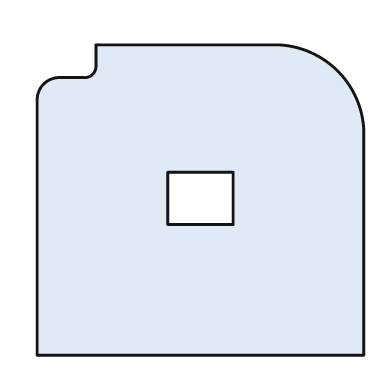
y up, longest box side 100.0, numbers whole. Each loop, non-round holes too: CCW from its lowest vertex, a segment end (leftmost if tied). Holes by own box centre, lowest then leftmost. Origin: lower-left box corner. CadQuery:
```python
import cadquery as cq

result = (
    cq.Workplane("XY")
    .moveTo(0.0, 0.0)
    .lineTo(100.0, 0.0)
    .lineTo(100.0, 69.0)
    .threePointArc((92.0, 87.0), (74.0, 95.0))
    .lineTo(18.0, 95.0)
    .lineTo(18.0, 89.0)
    .threePointArc((17.0, 86.0), (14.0, 85.0))
    .lineTo(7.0, 85.0)
    .threePointArc((2.0, 83.0), (0.0, 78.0))
    .close()
    .moveTo(40.0, 40.0)
    .lineTo(60.0, 40.0)
    .lineTo(60.0, 56.0)
    .lineTo(40.0, 56.0)
    .close()
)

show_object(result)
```